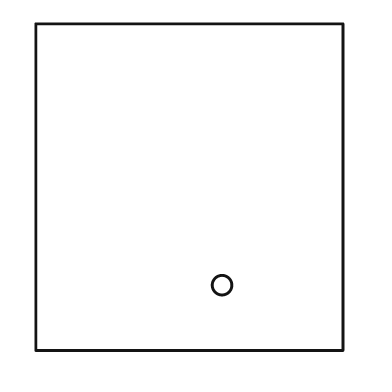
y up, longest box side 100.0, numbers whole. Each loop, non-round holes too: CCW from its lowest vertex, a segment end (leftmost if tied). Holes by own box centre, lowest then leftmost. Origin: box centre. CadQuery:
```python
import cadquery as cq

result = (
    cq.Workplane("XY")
    .moveTo(-47.0, -50.0)
    .lineTo(47.0, -50.0)
    .lineTo(47.0, 50.0)
    .lineTo(-47.0, 50.0)
    .close()
    .moveTo(10.0, -30.0)
    .circle(3.0)
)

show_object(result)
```